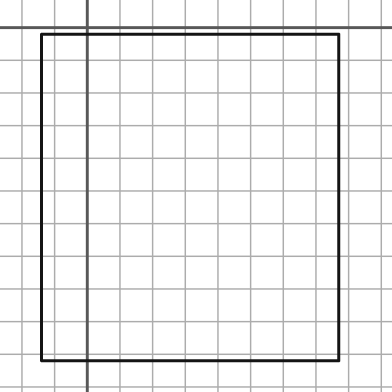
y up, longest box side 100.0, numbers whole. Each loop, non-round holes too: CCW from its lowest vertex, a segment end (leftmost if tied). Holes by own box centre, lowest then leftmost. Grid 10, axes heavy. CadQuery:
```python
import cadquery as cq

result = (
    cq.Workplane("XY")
    .moveTo(-14.0, -102.0)
    .lineTo(77.0, -102.0)
    .lineTo(77.0, -2.0)
    .lineTo(-14.0, -2.0)
    .close()
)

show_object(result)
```